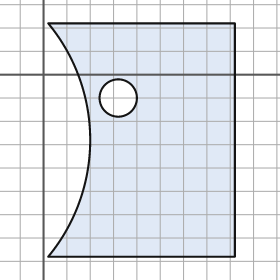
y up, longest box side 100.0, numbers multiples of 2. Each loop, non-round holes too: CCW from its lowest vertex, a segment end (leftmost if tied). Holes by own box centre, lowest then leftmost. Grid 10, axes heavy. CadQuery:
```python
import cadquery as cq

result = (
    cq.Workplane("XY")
    .moveTo(2.0, -78.0)
    .lineTo(82.0, -78.0)
    .lineTo(82.0, 22.0)
    .lineTo(2.0, 22.0)
    .threePointArc((20.0, -28.0), (2.0, -78.0))
    .close()
    .moveTo(32.0, -10.0)
    .circle(8.0)
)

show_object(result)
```